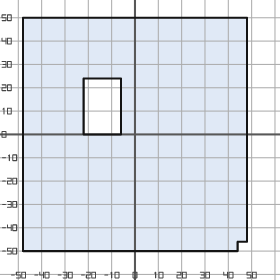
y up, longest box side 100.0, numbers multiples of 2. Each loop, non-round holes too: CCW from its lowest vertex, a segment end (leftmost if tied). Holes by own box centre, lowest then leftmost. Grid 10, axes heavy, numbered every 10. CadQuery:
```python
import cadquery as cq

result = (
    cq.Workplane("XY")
    .moveTo(-48.0, -50.0)
    .lineTo(44.0, -50.0)
    .lineTo(44.0, -46.0)
    .lineTo(48.0, -46.0)
    .lineTo(48.0, 50.0)
    .lineTo(-48.0, 50.0)
    .close()
    .moveTo(-22.0, 0.0)
    .lineTo(-6.0, 0.0)
    .lineTo(-6.0, 24.0)
    .lineTo(-22.0, 24.0)
    .close()
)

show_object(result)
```